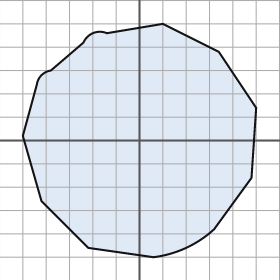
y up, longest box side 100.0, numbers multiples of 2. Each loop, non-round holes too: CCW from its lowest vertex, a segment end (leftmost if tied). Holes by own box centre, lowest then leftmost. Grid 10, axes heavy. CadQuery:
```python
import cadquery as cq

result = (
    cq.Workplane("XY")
    .moveTo(6.0, -50.0)
    .threePointArc((20.0, -46.0), (32.0, -38.0))
    .lineTo(48.0, -16.0)
    .lineTo(50.0, 14.0)
    .lineTo(34.0, 38.0)
    .lineTo(10.0, 50.0)
    .lineTo(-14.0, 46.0)
    .threePointArc((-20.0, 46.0), (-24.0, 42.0))
    .lineTo(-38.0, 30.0)
    .threePointArc((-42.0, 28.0), (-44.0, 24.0))
    .lineTo(-50.0, 2.0)
    .lineTo(-42.0, -26.0)
    .lineTo(-22.0, -46.0)
    .close()
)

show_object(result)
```